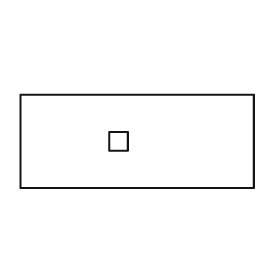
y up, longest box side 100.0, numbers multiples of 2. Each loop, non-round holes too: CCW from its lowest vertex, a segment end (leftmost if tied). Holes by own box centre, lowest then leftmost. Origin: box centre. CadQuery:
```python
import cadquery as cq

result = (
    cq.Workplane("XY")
    .moveTo(-50.0, -20.0)
    .lineTo(50.0, -20.0)
    .lineTo(50.0, 20.0)
    .lineTo(-50.0, 20.0)
    .close()
    .moveTo(-12.0, -4.0)
    .lineTo(-4.0, -4.0)
    .lineTo(-4.0, 4.0)
    .lineTo(-12.0, 4.0)
    .close()
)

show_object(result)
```